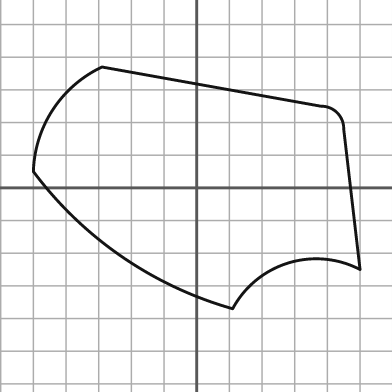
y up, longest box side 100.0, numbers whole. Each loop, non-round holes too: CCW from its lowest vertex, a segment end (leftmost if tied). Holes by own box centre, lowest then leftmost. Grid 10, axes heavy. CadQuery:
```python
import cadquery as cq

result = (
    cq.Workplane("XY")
    .moveTo(11.0, -37.0)
    .threePointArc((28.0, -23.0), (50.0, -25.0))
    .lineTo(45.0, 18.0)
    .threePointArc((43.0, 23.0), (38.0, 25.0))
    .lineTo(-29.0, 37.0)
    .threePointArc((-44.0, 24.0), (-50.0, 5.0))
    .threePointArc((-23.0, -21.0), (11.0, -37.0))
    .close()
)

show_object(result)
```